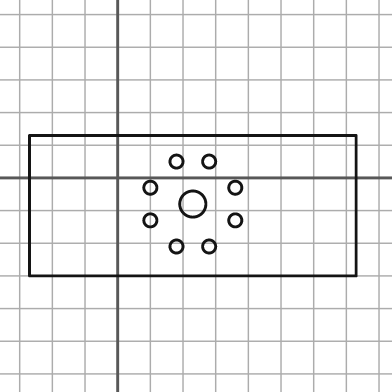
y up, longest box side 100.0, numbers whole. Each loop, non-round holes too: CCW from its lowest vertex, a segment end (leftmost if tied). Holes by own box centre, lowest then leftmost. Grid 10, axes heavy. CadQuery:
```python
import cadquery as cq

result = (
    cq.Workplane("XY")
    .moveTo(-27.0, -30.0)
    .lineTo(73.0, -30.0)
    .lineTo(73.0, 13.0)
    .lineTo(-27.0, 13.0)
    .close()
    .moveTo(18.0, -21.0)
    .circle(2.0)
    .moveTo(28.0, -21.0)
    .circle(2.0)
    .moveTo(10.0, -13.0)
    .circle(2.0)
    .moveTo(36.0, -13.0)
    .circle(2.0)
    .moveTo(23.0, -8.0)
    .circle(4.0)
    .moveTo(10.0, -3.0)
    .circle(2.0)
    .moveTo(36.0, -3.0)
    .circle(2.0)
    .moveTo(18.0, 5.0)
    .circle(2.0)
    .moveTo(28.0, 5.0)
    .circle(2.0)
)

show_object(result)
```